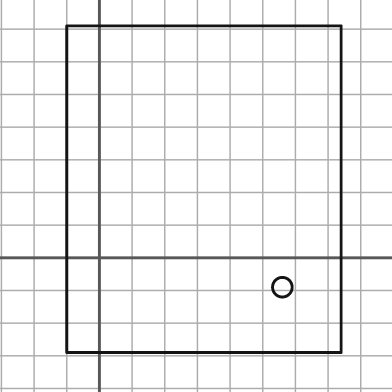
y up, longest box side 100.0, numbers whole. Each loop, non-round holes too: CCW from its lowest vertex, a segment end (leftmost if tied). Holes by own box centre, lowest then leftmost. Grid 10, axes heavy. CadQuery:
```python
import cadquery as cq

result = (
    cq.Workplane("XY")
    .moveTo(-10.0, -29.0)
    .lineTo(74.0, -29.0)
    .lineTo(74.0, 71.0)
    .lineTo(-10.0, 71.0)
    .close()
    .moveTo(56.0, -9.0)
    .circle(3.0)
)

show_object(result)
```